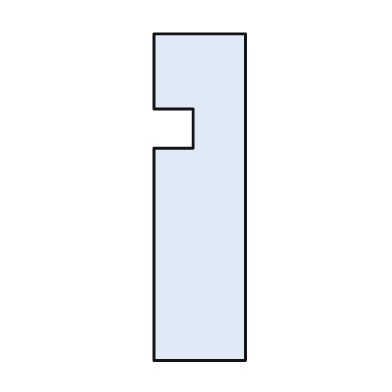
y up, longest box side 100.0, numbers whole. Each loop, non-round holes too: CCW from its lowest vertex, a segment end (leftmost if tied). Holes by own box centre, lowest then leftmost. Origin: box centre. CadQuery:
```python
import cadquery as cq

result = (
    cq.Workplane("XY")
    .moveTo(-14.0, -50.0)
    .lineTo(14.0, -50.0)
    .lineTo(14.0, 50.0)
    .lineTo(-14.0, 50.0)
    .lineTo(-14.0, 27.0)
    .lineTo(-2.0, 27.0)
    .lineTo(-2.0, 15.0)
    .lineTo(-14.0, 15.0)
    .close()
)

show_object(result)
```